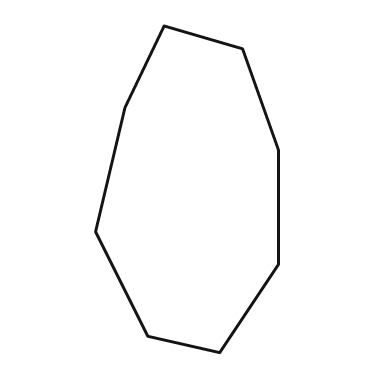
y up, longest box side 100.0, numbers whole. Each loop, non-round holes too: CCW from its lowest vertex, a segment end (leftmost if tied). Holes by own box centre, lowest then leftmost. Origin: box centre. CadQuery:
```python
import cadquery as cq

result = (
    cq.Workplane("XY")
    .moveTo(10.0, -50.0)
    .lineTo(28.0, -23.0)
    .lineTo(28.0, 12.0)
    .lineTo(17.0, 43.0)
    .lineTo(-7.0, 50.0)
    .lineTo(-19.0, 25.0)
    .lineTo(-28.0, -13.0)
    .lineTo(-12.0, -45.0)
    .close()
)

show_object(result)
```